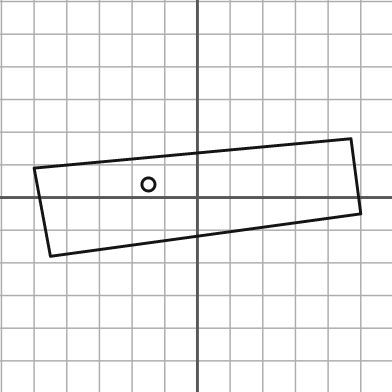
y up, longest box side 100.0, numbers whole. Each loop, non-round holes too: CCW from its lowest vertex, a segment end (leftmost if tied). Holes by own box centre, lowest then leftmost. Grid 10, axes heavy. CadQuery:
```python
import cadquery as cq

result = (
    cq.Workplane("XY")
    .moveTo(-45.0, -18.0)
    .lineTo(50.0, -5.0)
    .lineTo(47.0, 18.0)
    .lineTo(-50.0, 9.0)
    .close()
    .moveTo(-15.0, 4.0)
    .circle(2.0)
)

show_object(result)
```